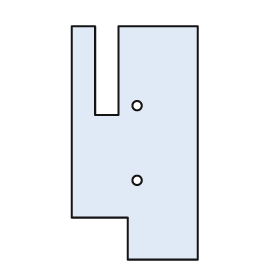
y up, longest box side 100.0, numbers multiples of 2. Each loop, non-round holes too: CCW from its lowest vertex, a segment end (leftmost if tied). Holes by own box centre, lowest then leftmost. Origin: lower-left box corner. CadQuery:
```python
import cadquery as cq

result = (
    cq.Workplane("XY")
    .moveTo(24.0, 0.0)
    .lineTo(54.0, 0.0)
    .lineTo(54.0, 100.0)
    .lineTo(20.0, 100.0)
    .lineTo(20.0, 62.0)
    .lineTo(10.0, 62.0)
    .lineTo(10.0, 100.0)
    .lineTo(0.0, 100.0)
    .lineTo(0.0, 18.0)
    .lineTo(24.0, 18.0)
    .close()
    .moveTo(28.0, 34.0)
    .circle(2.0)
    .moveTo(28.0, 66.0)
    .circle(2.0)
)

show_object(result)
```